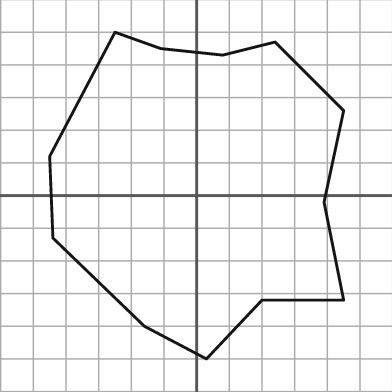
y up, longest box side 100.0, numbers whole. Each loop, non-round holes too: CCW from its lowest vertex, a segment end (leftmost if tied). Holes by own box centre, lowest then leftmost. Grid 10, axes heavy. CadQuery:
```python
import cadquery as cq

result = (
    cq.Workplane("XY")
    .moveTo(3.0, -50.0)
    .lineTo(20.0, -32.0)
    .lineTo(45.0, -32.0)
    .lineTo(39.0, -2.0)
    .lineTo(45.0, 26.0)
    .lineTo(24.0, 47.0)
    .lineTo(8.0, 43.0)
    .lineTo(-11.0, 45.0)
    .lineTo(-25.0, 50.0)
    .lineTo(-45.0, 12.0)
    .lineTo(-44.0, -13.0)
    .lineTo(-16.0, -40.0)
    .close()
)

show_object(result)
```